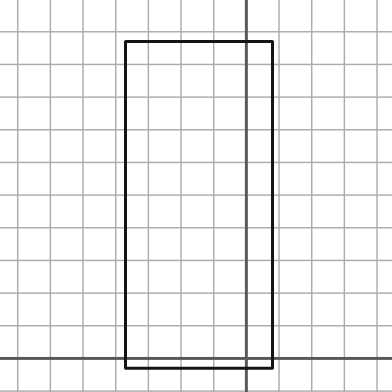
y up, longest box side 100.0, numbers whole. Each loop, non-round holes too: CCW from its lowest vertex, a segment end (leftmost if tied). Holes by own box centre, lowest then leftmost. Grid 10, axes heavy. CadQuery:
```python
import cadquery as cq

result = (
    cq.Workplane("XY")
    .moveTo(-37.0, -3.0)
    .lineTo(8.0, -3.0)
    .lineTo(8.0, 97.0)
    .lineTo(-37.0, 97.0)
    .close()
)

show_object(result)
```